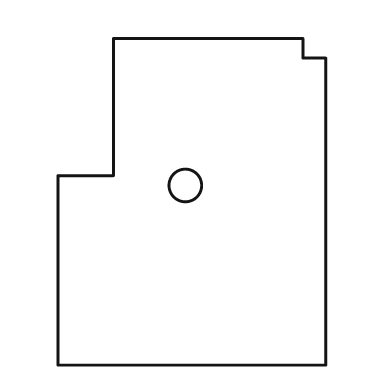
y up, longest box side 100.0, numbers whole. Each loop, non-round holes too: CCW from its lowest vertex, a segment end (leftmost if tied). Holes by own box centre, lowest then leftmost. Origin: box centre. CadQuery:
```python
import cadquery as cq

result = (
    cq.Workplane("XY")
    .moveTo(-41.0, -50.0)
    .lineTo(41.0, -50.0)
    .lineTo(41.0, 44.0)
    .lineTo(34.0, 44.0)
    .lineTo(34.0, 50.0)
    .lineTo(-24.0, 50.0)
    .lineTo(-24.0, 8.0)
    .lineTo(-41.0, 8.0)
    .close()
    .moveTo(-2.0, 5.0)
    .circle(5.0)
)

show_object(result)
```